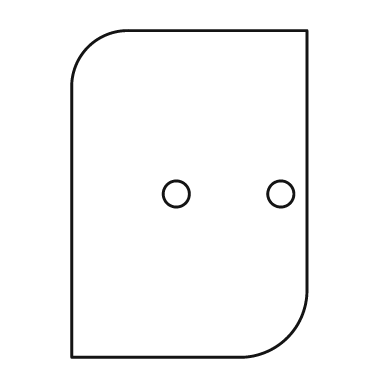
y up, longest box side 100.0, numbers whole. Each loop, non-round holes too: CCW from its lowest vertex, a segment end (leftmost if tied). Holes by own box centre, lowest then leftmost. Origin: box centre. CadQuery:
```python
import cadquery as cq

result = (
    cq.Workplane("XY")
    .moveTo(-36.0, -50.0)
    .lineTo(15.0, -50.0)
    .threePointArc((30.0, -44.0), (36.0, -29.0))
    .lineTo(36.0, 50.0)
    .lineTo(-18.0, 50.0)
    .threePointArc((-31.0, 45.0), (-36.0, 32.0))
    .close()
    .moveTo(-4.0, 0.0)
    .circle(4.0)
    .moveTo(28.0, 0.0)
    .circle(4.0)
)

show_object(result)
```